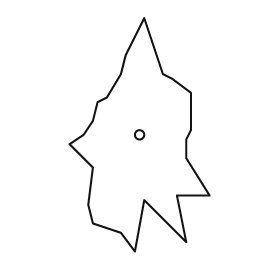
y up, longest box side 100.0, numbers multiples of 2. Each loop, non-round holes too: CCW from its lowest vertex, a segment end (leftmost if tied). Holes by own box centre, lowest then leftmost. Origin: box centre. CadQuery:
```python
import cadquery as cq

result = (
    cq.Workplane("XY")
    .moveTo(-2.0, -50.0)
    .lineTo(2.0, -28.0)
    .lineTo(20.0, -46.0)
    .lineTo(16.0, -26.0)
    .lineTo(30.0, -26.0)
    .lineTo(20.0, -10.0)
    .lineTo(20.0, -2.0)
    .lineTo(22.0, 2.0)
    .lineTo(22.0, 18.0)
    .lineTo(14.0, 24.0)
    .lineTo(10.0, 26.0)
    .lineTo(2.0, 50.0)
    .lineTo(-6.0, 34.0)
    .lineTo(-8.0, 26.0)
    .lineTo(-14.0, 16.0)
    .lineTo(-18.0, 14.0)
    .lineTo(-20.0, 6.0)
    .lineTo(-24.0, 0.0)
    .lineTo(-30.0, -4.0)
    .lineTo(-20.0, -14.0)
    .lineTo(-22.0, -30.0)
    .lineTo(-20.0, -38.0)
    .lineTo(-8.0, -42.0)
    .close()
    .moveTo(0.0, 0.0)
    .circle(2.0)
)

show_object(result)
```